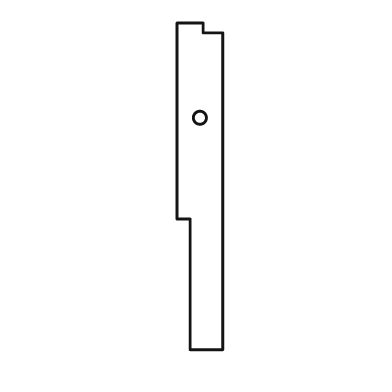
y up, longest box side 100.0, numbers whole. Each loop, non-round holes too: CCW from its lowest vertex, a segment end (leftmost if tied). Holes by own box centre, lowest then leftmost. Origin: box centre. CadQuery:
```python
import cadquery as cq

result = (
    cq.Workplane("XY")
    .moveTo(-3.0, -50.0)
    .lineTo(7.0, -50.0)
    .lineTo(7.0, 47.0)
    .lineTo(1.0, 47.0)
    .lineTo(1.0, 50.0)
    .lineTo(-7.0, 50.0)
    .lineTo(-7.0, -10.0)
    .lineTo(-3.0, -10.0)
    .close()
    .moveTo(0.0, 21.0)
    .circle(2.0)
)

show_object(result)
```